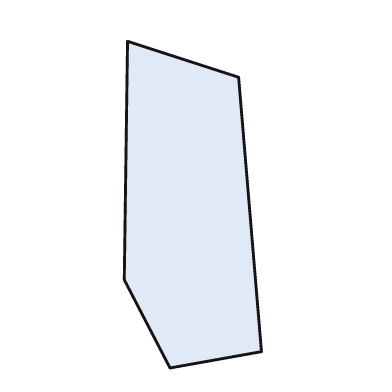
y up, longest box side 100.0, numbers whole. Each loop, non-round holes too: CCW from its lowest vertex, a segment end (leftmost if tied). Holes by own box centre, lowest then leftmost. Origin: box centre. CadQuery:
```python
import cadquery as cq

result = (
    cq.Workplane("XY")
    .moveTo(-7.0, -50.0)
    .lineTo(21.0, -45.0)
    .lineTo(14.0, 39.0)
    .lineTo(-20.0, 50.0)
    .lineTo(-21.0, -23.0)
    .close()
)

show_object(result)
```